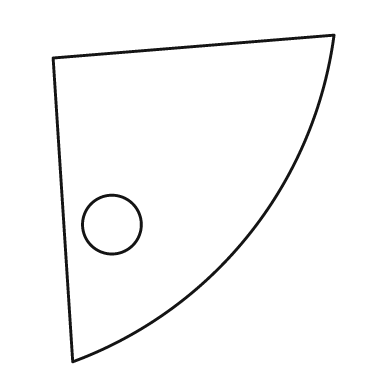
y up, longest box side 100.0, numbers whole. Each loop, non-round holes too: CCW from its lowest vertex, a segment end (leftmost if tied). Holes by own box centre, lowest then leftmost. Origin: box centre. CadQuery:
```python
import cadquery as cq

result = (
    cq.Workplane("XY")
    .moveTo(-37.0, -50.0)
    .threePointArc((17.0, -11.0), (43.0, 50.0))
    .lineTo(-43.0, 43.0)
    .close()
    .moveTo(-25.0, -8.0)
    .circle(9.0)
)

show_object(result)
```